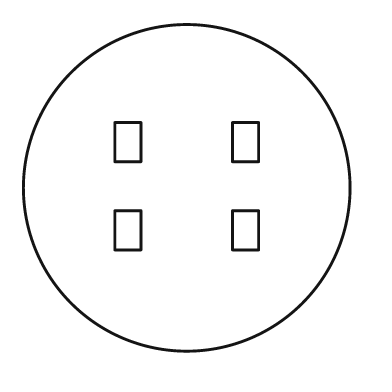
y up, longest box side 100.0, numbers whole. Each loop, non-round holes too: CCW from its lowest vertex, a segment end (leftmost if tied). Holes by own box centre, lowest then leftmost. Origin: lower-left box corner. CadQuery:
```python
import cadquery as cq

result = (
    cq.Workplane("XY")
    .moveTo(50.0, 50.0)
    .circle(50.0)
    .moveTo(28.0, 31.0)
    .lineTo(36.0, 31.0)
    .lineTo(36.0, 43.0)
    .lineTo(28.0, 43.0)
    .close()
    .moveTo(64.0, 31.0)
    .lineTo(72.0, 31.0)
    .lineTo(72.0, 43.0)
    .lineTo(64.0, 43.0)
    .close()
    .moveTo(28.0, 58.0)
    .lineTo(36.0, 58.0)
    .lineTo(36.0, 70.0)
    .lineTo(28.0, 70.0)
    .close()
    .moveTo(64.0, 58.0)
    .lineTo(72.0, 58.0)
    .lineTo(72.0, 70.0)
    .lineTo(64.0, 70.0)
    .close()
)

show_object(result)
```